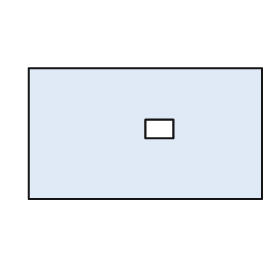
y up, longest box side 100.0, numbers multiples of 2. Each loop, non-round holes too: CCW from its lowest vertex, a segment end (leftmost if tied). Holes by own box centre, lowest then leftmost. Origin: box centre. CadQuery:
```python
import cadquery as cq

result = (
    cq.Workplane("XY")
    .moveTo(-50.0, -28.0)
    .lineTo(50.0, -28.0)
    .lineTo(50.0, 28.0)
    .lineTo(-50.0, 28.0)
    .close()
    .moveTo(0.0, -2.0)
    .lineTo(12.0, -2.0)
    .lineTo(12.0, 6.0)
    .lineTo(0.0, 6.0)
    .close()
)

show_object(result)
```